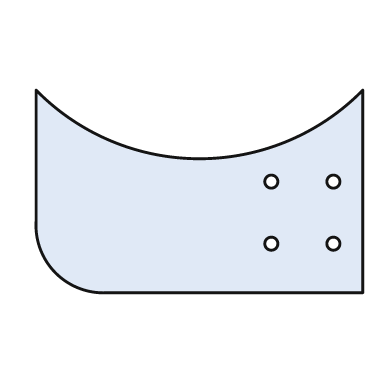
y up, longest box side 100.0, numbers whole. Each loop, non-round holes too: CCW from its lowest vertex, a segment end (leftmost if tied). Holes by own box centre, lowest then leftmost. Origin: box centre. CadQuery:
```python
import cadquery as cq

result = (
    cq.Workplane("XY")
    .moveTo(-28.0, -31.0)
    .lineTo(50.0, -31.0)
    .lineTo(50.0, 31.0)
    .threePointArc((0.0, 10.0), (-50.0, 31.0))
    .lineTo(-50.0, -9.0)
    .threePointArc((-44.0, -25.0), (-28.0, -31.0))
    .close()
    .moveTo(22.0, -16.0)
    .circle(2.0)
    .moveTo(41.0, -16.0)
    .circle(2.0)
    .moveTo(22.0, 3.0)
    .circle(2.0)
    .moveTo(41.0, 3.0)
    .circle(2.0)
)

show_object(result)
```